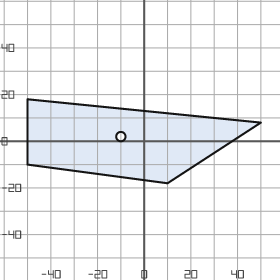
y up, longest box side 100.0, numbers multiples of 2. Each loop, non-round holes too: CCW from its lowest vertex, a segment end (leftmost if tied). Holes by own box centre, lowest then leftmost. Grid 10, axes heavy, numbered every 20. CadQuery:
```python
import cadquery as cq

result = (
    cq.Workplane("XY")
    .moveTo(10.0, -18.0)
    .lineTo(50.0, 8.0)
    .lineTo(-50.0, 18.0)
    .lineTo(-50.0, -10.0)
    .close()
    .moveTo(-10.0, 2.0)
    .circle(2.0)
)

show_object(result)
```